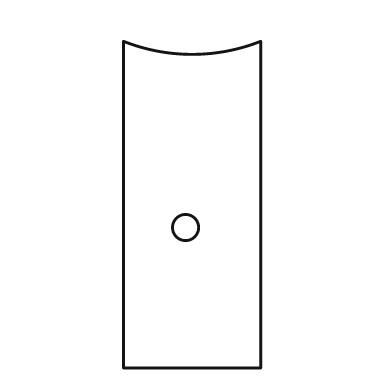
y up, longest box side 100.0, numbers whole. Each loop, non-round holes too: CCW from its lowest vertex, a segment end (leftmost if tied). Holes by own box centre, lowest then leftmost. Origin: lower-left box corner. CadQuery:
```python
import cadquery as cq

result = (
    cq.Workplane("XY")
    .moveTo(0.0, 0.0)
    .lineTo(42.0, 0.0)
    .lineTo(42.0, 100.0)
    .threePointArc((21.0, 96.0), (0.0, 100.0))
    .close()
    .moveTo(19.0, 43.0)
    .circle(4.0)
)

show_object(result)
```